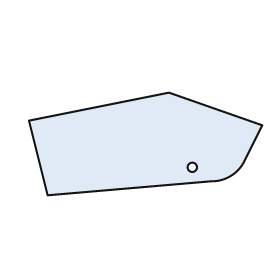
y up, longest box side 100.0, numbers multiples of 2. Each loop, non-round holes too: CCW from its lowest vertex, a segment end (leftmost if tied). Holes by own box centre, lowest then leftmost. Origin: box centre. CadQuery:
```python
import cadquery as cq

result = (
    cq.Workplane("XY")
    .moveTo(-42.0, -22.0)
    .lineTo(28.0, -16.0)
    .threePointArc((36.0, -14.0), (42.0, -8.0))
    .lineTo(50.0, 8.0)
    .lineTo(10.0, 22.0)
    .lineTo(-50.0, 10.0)
    .close()
    .moveTo(20.0, -10.0)
    .circle(2.0)
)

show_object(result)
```